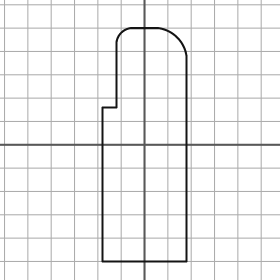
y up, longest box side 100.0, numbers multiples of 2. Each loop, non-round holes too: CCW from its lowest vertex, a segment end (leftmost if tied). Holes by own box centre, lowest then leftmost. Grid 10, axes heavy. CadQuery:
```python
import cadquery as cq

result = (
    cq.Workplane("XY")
    .moveTo(-18.0, -50.0)
    .lineTo(18.0, -50.0)
    .lineTo(18.0, 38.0)
    .threePointArc((14.0, 46.0), (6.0, 50.0))
    .lineTo(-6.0, 50.0)
    .threePointArc((-10.0, 48.0), (-12.0, 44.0))
    .lineTo(-12.0, 16.0)
    .lineTo(-18.0, 16.0)
    .close()
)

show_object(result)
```